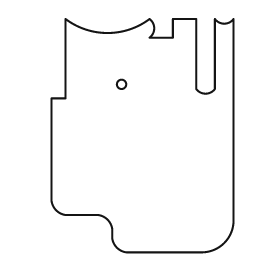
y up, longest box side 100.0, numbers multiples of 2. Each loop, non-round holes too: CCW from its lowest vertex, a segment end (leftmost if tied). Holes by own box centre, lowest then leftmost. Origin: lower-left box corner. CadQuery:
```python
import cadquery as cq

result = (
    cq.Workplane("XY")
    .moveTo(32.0, 0.0)
    .lineTo(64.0, 0.0)
    .threePointArc((74.0, 4.0), (78.0, 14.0))
    .lineTo(78.0, 100.0)
    .threePointArc((74.0, 98.0), (70.0, 100.0))
    .lineTo(70.0, 70.0)
    .threePointArc((66.0, 68.0), (62.0, 70.0))
    .lineTo(62.0, 100.0)
    .lineTo(52.0, 100.0)
    .lineTo(52.0, 92.0)
    .lineTo(42.0, 92.0)
    .threePointArc((44.0, 96.0), (42.0, 100.0))
    .threePointArc((24.0, 94.0), (6.0, 100.0))
    .lineTo(6.0, 66.0)
    .lineTo(0.0, 66.0)
    .lineTo(0.0, 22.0)
    .threePointArc((2.0, 18.0), (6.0, 16.0))
    .lineTo(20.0, 16.0)
    .threePointArc((24.0, 14.0), (26.0, 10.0))
    .lineTo(26.0, 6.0)
    .threePointArc((28.0, 2.0), (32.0, 0.0))
    .close()
    .moveTo(30.0, 72.0)
    .circle(2.0)
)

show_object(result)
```